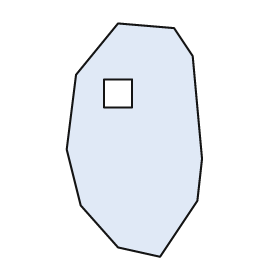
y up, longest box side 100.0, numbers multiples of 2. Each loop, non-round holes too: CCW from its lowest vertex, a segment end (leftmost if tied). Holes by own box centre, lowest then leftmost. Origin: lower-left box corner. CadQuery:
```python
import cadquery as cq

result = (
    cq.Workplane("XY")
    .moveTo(40.0, 0.0)
    .lineTo(56.0, 24.0)
    .lineTo(58.0, 42.0)
    .lineTo(54.0, 86.0)
    .lineTo(46.0, 98.0)
    .lineTo(22.0, 100.0)
    .lineTo(4.0, 78.0)
    .lineTo(0.0, 46.0)
    .lineTo(6.0, 22.0)
    .lineTo(22.0, 4.0)
    .close()
    .moveTo(16.0, 64.0)
    .lineTo(28.0, 64.0)
    .lineTo(28.0, 76.0)
    .lineTo(16.0, 76.0)
    .close()
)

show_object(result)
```